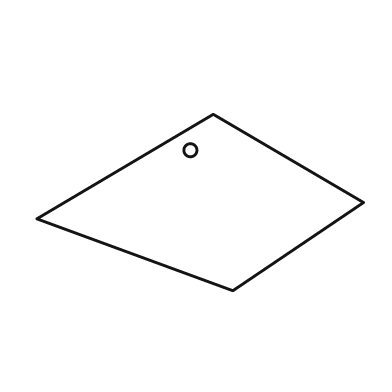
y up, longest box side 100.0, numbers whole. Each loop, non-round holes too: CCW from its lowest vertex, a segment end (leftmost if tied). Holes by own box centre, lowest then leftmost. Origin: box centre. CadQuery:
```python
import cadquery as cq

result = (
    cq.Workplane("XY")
    .moveTo(10.0, -27.0)
    .lineTo(50.0, 0.0)
    .lineTo(4.0, 27.0)
    .lineTo(-50.0, -5.0)
    .close()
    .moveTo(-3.0, 16.0)
    .circle(2.0)
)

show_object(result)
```